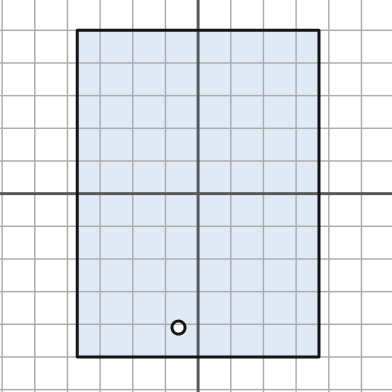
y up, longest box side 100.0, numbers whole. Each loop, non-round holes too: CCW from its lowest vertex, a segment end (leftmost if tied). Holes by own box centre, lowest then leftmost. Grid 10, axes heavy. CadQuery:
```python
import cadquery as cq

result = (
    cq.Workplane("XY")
    .moveTo(-37.0, -50.0)
    .lineTo(37.0, -50.0)
    .lineTo(37.0, 50.0)
    .lineTo(-37.0, 50.0)
    .close()
    .moveTo(-6.0, -41.0)
    .circle(2.0)
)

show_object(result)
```